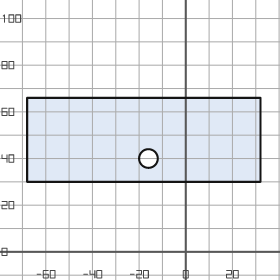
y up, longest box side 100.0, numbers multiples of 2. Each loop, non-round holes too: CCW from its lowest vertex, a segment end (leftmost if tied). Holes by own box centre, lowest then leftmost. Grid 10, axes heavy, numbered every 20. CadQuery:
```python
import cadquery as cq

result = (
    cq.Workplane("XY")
    .moveTo(-68.0, 30.0)
    .lineTo(32.0, 30.0)
    .lineTo(32.0, 66.0)
    .lineTo(-68.0, 66.0)
    .close()
    .moveTo(-16.0, 40.0)
    .circle(4.0)
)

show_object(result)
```